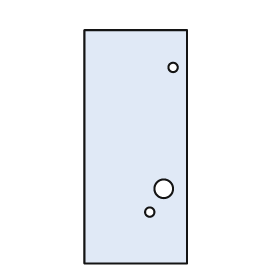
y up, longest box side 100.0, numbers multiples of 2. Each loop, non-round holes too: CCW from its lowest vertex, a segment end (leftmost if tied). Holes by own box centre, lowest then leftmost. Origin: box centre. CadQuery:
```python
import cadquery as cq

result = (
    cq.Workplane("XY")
    .moveTo(-22.0, -50.0)
    .lineTo(22.0, -50.0)
    .lineTo(22.0, 50.0)
    .lineTo(-22.0, 50.0)
    .close()
    .moveTo(6.0, -28.0)
    .circle(2.0)
    .moveTo(12.0, -18.0)
    .circle(4.0)
    .moveTo(16.0, 34.0)
    .circle(2.0)
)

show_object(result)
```